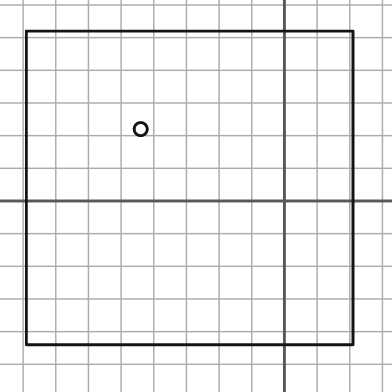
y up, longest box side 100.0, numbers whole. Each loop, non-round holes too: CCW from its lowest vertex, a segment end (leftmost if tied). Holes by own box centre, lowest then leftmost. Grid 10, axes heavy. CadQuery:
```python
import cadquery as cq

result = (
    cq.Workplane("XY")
    .moveTo(-79.0, -44.0)
    .lineTo(21.0, -44.0)
    .lineTo(21.0, 52.0)
    .lineTo(-79.0, 52.0)
    .close()
    .moveTo(-44.0, 22.0)
    .circle(2.0)
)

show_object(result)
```